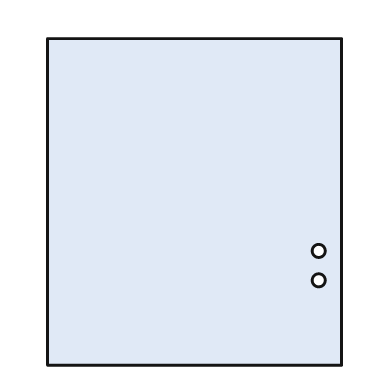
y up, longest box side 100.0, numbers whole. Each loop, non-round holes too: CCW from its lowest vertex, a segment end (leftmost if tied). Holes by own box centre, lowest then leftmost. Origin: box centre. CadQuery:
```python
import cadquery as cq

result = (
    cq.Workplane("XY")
    .moveTo(-45.0, -50.0)
    .lineTo(45.0, -50.0)
    .lineTo(45.0, 50.0)
    .lineTo(-45.0, 50.0)
    .close()
    .moveTo(38.0, -24.0)
    .circle(2.0)
    .moveTo(38.0, -15.0)
    .circle(2.0)
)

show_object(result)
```